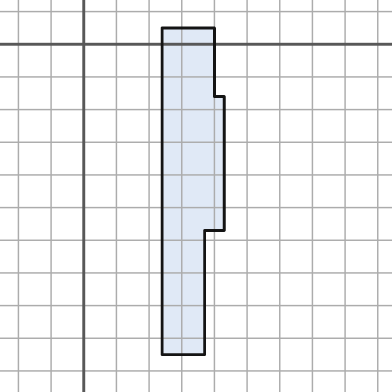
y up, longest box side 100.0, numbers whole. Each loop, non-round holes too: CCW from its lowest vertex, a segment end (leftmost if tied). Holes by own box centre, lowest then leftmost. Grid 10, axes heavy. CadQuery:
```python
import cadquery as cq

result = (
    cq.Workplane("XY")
    .moveTo(24.0, -95.0)
    .lineTo(37.0, -95.0)
    .lineTo(37.0, -57.0)
    .lineTo(43.0, -57.0)
    .lineTo(43.0, -16.0)
    .lineTo(40.0, -16.0)
    .lineTo(40.0, 5.0)
    .lineTo(24.0, 5.0)
    .close()
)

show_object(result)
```